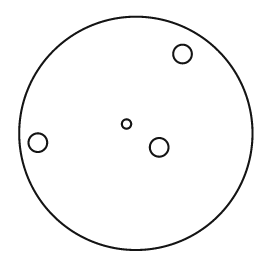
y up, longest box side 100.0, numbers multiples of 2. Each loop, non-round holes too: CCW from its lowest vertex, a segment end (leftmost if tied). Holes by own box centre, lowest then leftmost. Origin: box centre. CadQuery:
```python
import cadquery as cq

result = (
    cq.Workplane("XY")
    .moveTo(0.0, 0.0)
    .circle(50.0)
    .moveTo(10.0, -6.0)
    .circle(4.0)
    .moveTo(-42.0, -4.0)
    .circle(4.0)
    .moveTo(-4.0, 4.0)
    .circle(2.0)
    .moveTo(20.0, 34.0)
    .circle(4.0)
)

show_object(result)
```